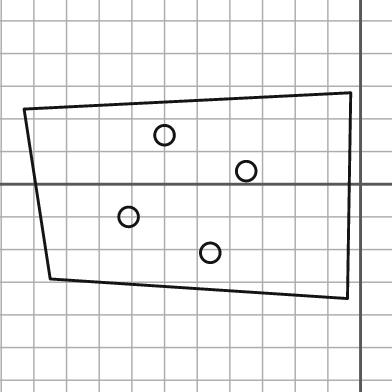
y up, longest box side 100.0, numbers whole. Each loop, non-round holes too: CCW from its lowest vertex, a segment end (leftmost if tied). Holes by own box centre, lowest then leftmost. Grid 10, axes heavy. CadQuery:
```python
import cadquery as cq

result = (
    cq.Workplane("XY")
    .moveTo(-4.0, -35.0)
    .lineTo(-3.0, 28.0)
    .lineTo(-103.0, 23.0)
    .lineTo(-95.0, -29.0)
    .close()
    .moveTo(-46.0, -21.0)
    .circle(3.0)
    .moveTo(-71.0, -10.0)
    .circle(3.0)
    .moveTo(-35.0, 4.0)
    .circle(3.0)
    .moveTo(-60.0, 15.0)
    .circle(3.0)
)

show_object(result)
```